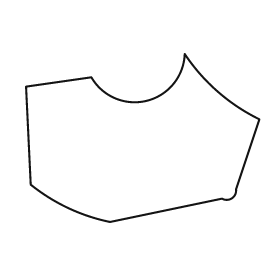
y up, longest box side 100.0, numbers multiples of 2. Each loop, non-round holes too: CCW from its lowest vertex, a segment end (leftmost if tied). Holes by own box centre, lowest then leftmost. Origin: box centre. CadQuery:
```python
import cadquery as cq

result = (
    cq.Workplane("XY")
    .moveTo(-14.0, -36.0)
    .lineTo(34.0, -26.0)
    .threePointArc((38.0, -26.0), (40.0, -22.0))
    .lineTo(50.0, 8.0)
    .threePointArc((32.0, 20.0), (18.0, 36.0))
    .threePointArc((2.0, 16.0), (-22.0, 26.0))
    .lineTo(-50.0, 22.0)
    .lineTo(-48.0, -20.0)
    .threePointArc((-32.0, -30.0), (-14.0, -36.0))
    .close()
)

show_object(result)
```